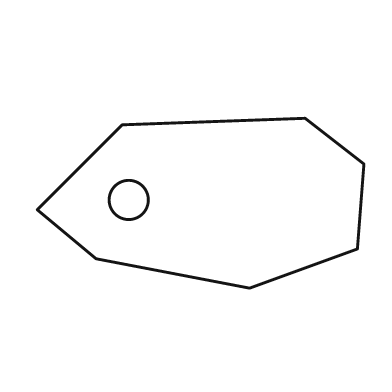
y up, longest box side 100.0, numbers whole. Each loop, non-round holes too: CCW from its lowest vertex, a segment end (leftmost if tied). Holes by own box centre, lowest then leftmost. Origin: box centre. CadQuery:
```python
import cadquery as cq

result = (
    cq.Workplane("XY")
    .moveTo(15.0, -26.0)
    .lineTo(48.0, -14.0)
    .lineTo(50.0, 12.0)
    .lineTo(32.0, 26.0)
    .lineTo(-24.0, 24.0)
    .lineTo(-50.0, -2.0)
    .lineTo(-32.0, -17.0)
    .close()
    .moveTo(-22.0, 1.0)
    .circle(6.0)
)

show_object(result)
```